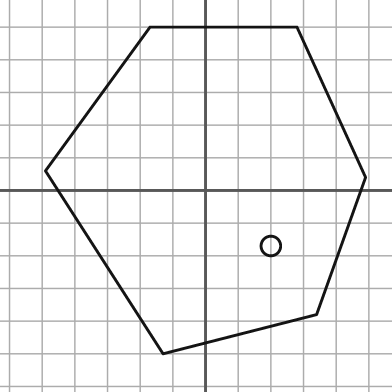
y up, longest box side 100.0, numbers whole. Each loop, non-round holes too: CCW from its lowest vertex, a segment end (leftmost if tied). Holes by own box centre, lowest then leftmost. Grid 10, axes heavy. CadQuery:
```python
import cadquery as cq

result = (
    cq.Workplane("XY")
    .moveTo(-13.0, -50.0)
    .lineTo(34.0, -38.0)
    .lineTo(49.0, 4.0)
    .lineTo(28.0, 50.0)
    .lineTo(-17.0, 50.0)
    .lineTo(-49.0, 6.0)
    .close()
    .moveTo(20.0, -17.0)
    .circle(3.0)
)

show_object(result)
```